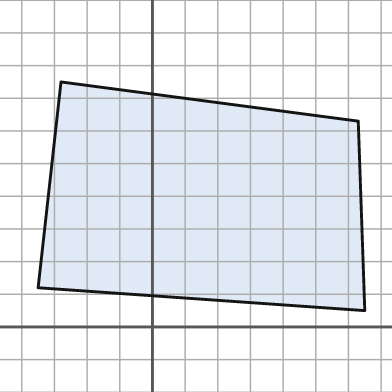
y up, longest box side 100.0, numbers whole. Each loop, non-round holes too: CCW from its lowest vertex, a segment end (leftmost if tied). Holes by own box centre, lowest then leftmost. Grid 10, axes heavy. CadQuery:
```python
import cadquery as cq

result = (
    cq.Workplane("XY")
    .moveTo(65.0, 5.0)
    .lineTo(63.0, 63.0)
    .lineTo(-28.0, 75.0)
    .lineTo(-35.0, 12.0)
    .close()
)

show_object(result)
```